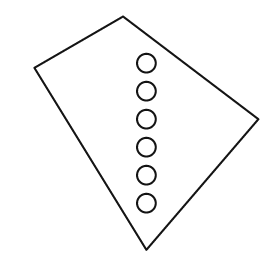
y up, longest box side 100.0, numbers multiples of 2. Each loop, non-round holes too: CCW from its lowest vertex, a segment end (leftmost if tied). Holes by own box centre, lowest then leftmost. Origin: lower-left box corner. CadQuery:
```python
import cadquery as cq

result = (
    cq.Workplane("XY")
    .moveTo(48.0, 0.0)
    .lineTo(96.0, 56.0)
    .lineTo(38.0, 100.0)
    .lineTo(0.0, 78.0)
    .close()
    .moveTo(48.0, 20.0)
    .circle(4.0)
    .moveTo(48.0, 32.0)
    .circle(4.0)
    .moveTo(48.0, 44.0)
    .circle(4.0)
    .moveTo(48.0, 56.0)
    .circle(4.0)
    .moveTo(48.0, 68.0)
    .circle(4.0)
    .moveTo(48.0, 80.0)
    .circle(4.0)
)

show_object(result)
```